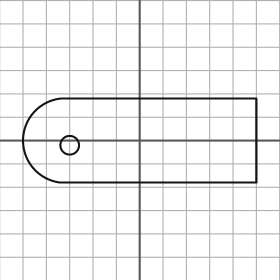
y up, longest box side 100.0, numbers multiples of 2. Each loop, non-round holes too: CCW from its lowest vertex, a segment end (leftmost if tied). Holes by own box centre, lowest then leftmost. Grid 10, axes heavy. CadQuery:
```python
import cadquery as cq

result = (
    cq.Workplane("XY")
    .moveTo(-34.0, -18.0)
    .lineTo(50.0, -18.0)
    .lineTo(50.0, 18.0)
    .lineTo(-34.0, 18.0)
    .threePointArc((-50.0, 0.0), (-34.0, -18.0))
    .close()
    .moveTo(-30.0, -2.0)
    .circle(4.0)
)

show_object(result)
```